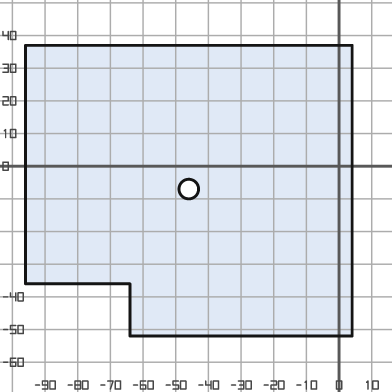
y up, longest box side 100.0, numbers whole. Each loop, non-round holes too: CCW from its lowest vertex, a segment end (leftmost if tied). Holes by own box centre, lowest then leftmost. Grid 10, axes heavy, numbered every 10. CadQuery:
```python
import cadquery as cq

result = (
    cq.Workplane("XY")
    .moveTo(-64.0, -52.0)
    .lineTo(4.0, -52.0)
    .lineTo(4.0, 37.0)
    .lineTo(-96.0, 37.0)
    .lineTo(-96.0, -36.0)
    .lineTo(-64.0, -36.0)
    .close()
    .moveTo(-46.0, -7.0)
    .circle(3.0)
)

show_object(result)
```